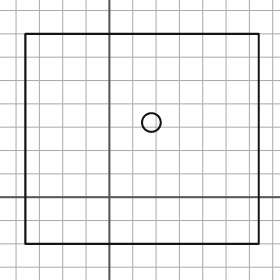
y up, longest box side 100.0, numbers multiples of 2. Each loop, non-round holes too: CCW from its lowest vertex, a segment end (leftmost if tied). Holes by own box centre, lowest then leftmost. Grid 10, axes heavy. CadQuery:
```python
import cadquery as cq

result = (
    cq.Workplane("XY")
    .moveTo(-36.0, -20.0)
    .lineTo(64.0, -20.0)
    .lineTo(64.0, 70.0)
    .lineTo(-36.0, 70.0)
    .close()
    .moveTo(18.0, 32.0)
    .circle(4.0)
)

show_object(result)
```